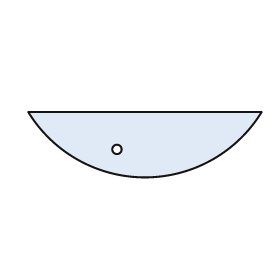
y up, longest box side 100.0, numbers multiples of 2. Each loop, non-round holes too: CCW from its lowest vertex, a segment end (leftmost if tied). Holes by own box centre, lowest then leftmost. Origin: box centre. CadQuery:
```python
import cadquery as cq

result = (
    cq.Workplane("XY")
    .moveTo(-50.0, 14.0)
    .threePointArc((0.0, -14.0), (50.0, 14.0))
    .close()
    .moveTo(-12.0, -2.0)
    .circle(2.0)
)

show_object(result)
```